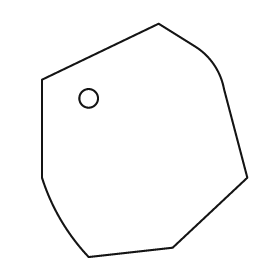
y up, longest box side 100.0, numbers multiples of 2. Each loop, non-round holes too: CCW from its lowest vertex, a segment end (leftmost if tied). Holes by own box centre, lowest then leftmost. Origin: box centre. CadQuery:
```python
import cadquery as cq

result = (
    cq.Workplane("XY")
    .moveTo(-24.0, -50.0)
    .lineTo(12.0, -46.0)
    .lineTo(44.0, -16.0)
    .lineTo(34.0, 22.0)
    .threePointArc((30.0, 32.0), (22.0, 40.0))
    .lineTo(6.0, 50.0)
    .lineTo(-44.0, 26.0)
    .lineTo(-44.0, -16.0)
    .threePointArc((-36.0, -34.0), (-24.0, -50.0))
    .close()
    .moveTo(-24.0, 18.0)
    .circle(4.0)
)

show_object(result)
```